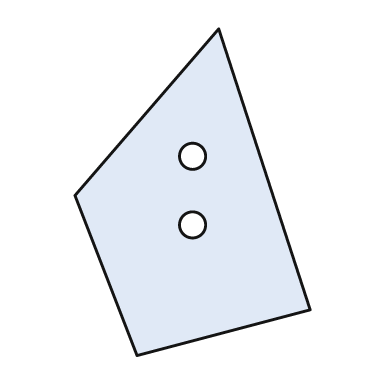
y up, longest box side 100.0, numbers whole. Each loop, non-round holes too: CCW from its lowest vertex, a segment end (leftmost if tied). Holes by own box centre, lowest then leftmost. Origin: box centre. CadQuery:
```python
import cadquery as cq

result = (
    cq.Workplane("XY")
    .moveTo(-17.0, -50.0)
    .lineTo(36.0, -36.0)
    .lineTo(8.0, 50.0)
    .lineTo(-36.0, -1.0)
    .close()
    .moveTo(0.0, -10.0)
    .circle(4.0)
    .moveTo(0.0, 11.0)
    .circle(4.0)
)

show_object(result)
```